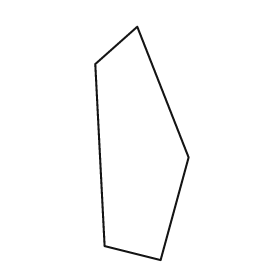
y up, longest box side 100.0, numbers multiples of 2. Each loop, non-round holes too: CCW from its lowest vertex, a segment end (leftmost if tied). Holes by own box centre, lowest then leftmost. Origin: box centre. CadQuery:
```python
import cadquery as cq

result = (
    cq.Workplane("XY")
    .moveTo(8.0, -50.0)
    .lineTo(20.0, -6.0)
    .lineTo(-2.0, 50.0)
    .lineTo(-20.0, 34.0)
    .lineTo(-16.0, -44.0)
    .close()
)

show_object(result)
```